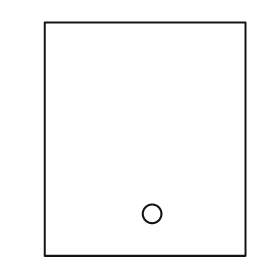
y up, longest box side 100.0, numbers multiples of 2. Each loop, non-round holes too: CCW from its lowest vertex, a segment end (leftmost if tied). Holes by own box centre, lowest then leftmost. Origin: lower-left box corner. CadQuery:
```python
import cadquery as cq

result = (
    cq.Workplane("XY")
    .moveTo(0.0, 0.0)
    .lineTo(86.0, 0.0)
    .lineTo(86.0, 100.0)
    .lineTo(0.0, 100.0)
    .close()
    .moveTo(46.0, 18.0)
    .circle(4.0)
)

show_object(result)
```